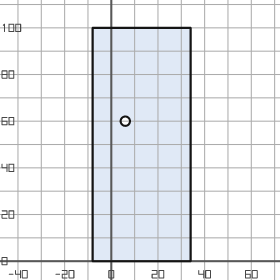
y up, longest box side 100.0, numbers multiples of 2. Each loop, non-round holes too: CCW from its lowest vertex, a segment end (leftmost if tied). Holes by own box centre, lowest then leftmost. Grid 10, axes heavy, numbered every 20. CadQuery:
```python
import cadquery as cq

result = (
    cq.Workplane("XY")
    .moveTo(-8.0, 0.0)
    .lineTo(34.0, 0.0)
    .lineTo(34.0, 100.0)
    .lineTo(-8.0, 100.0)
    .close()
    .moveTo(6.0, 60.0)
    .circle(2.0)
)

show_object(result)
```